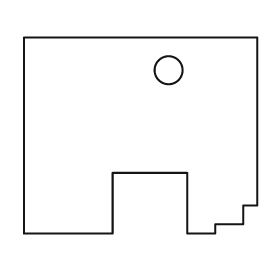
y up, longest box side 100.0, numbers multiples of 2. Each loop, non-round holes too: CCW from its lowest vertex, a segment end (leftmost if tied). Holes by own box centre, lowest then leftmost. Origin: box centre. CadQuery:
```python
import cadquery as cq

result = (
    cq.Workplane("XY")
    .moveTo(-50.0, -42.0)
    .lineTo(-12.0, -42.0)
    .lineTo(-12.0, -16.0)
    .lineTo(20.0, -16.0)
    .lineTo(20.0, -42.0)
    .lineTo(32.0, -42.0)
    .lineTo(32.0, -38.0)
    .lineTo(44.0, -38.0)
    .lineTo(44.0, -30.0)
    .lineTo(50.0, -30.0)
    .lineTo(50.0, 42.0)
    .lineTo(-50.0, 42.0)
    .close()
    .moveTo(12.0, 28.0)
    .circle(6.0)
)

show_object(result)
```